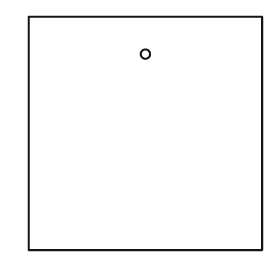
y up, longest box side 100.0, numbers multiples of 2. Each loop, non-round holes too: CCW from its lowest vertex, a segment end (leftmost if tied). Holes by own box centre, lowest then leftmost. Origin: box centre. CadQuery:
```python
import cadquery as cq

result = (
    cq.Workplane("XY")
    .moveTo(-50.0, -50.0)
    .lineTo(50.0, -50.0)
    .lineTo(50.0, 50.0)
    .lineTo(-50.0, 50.0)
    .close()
    .moveTo(0.0, 34.0)
    .circle(2.0)
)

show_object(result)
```